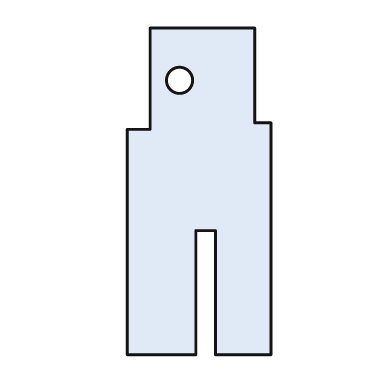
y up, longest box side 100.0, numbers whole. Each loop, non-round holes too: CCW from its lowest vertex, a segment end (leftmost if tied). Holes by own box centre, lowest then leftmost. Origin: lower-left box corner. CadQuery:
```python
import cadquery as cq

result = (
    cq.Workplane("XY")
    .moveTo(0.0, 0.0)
    .lineTo(21.0, 0.0)
    .lineTo(21.0, 38.0)
    .lineTo(27.0, 38.0)
    .lineTo(27.0, 0.0)
    .lineTo(44.0, 0.0)
    .lineTo(44.0, 71.0)
    .lineTo(39.0, 71.0)
    .lineTo(39.0, 100.0)
    .lineTo(7.0, 100.0)
    .lineTo(7.0, 69.0)
    .lineTo(0.0, 69.0)
    .close()
    .moveTo(16.0, 84.0)
    .circle(4.0)
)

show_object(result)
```